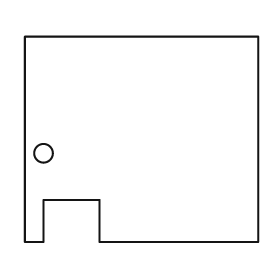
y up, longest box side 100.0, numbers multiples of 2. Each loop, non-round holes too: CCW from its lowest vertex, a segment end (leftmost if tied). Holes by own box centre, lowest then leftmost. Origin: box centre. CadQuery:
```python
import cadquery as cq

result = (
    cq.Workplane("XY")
    .moveTo(-50.0, -44.0)
    .lineTo(-42.0, -44.0)
    .lineTo(-42.0, -26.0)
    .lineTo(-18.0, -26.0)
    .lineTo(-18.0, -44.0)
    .lineTo(50.0, -44.0)
    .lineTo(50.0, 44.0)
    .lineTo(-50.0, 44.0)
    .close()
    .moveTo(-42.0, -6.0)
    .circle(4.0)
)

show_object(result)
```